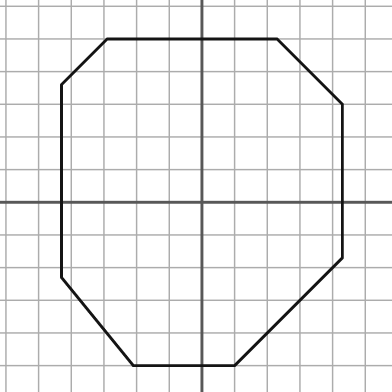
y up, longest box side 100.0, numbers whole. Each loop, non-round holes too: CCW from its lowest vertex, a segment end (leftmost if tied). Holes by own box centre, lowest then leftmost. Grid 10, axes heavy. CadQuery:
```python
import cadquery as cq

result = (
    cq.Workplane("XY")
    .moveTo(-21.0, -50.0)
    .lineTo(10.0, -50.0)
    .lineTo(43.0, -17.0)
    .lineTo(43.0, 30.0)
    .lineTo(23.0, 50.0)
    .lineTo(-29.0, 50.0)
    .lineTo(-43.0, 36.0)
    .lineTo(-43.0, -23.0)
    .close()
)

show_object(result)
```